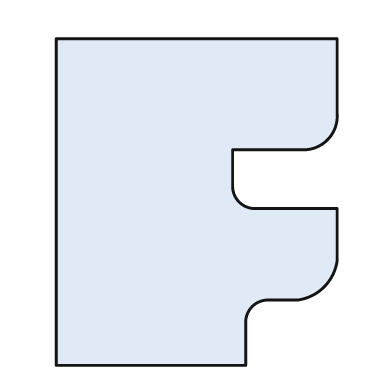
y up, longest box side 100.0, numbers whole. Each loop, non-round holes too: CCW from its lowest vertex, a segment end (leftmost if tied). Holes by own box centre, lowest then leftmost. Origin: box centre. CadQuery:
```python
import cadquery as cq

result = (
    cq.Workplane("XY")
    .moveTo(-43.0, -50.0)
    .lineTo(15.0, -50.0)
    .lineTo(15.0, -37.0)
    .threePointArc((17.0, -32.0), (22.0, -30.0))
    .lineTo(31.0, -30.0)
    .threePointArc((39.0, -26.0), (43.0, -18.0))
    .lineTo(43.0, -2.0)
    .lineTo(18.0, -2.0)
    .threePointArc((13.0, 0.0), (11.0, 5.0))
    .lineTo(11.0, 16.0)
    .lineTo(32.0, 16.0)
    .threePointArc((40.0, 19.0), (43.0, 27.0))
    .lineTo(43.0, 50.0)
    .lineTo(-43.0, 50.0)
    .close()
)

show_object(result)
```